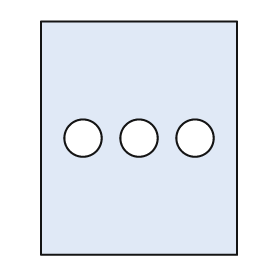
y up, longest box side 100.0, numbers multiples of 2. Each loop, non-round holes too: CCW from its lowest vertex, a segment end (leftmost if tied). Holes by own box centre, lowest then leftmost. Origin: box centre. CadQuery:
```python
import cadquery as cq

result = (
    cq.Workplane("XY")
    .moveTo(-42.0, -50.0)
    .lineTo(42.0, -50.0)
    .lineTo(42.0, 50.0)
    .lineTo(-42.0, 50.0)
    .close()
    .moveTo(-24.0, 0.0)
    .circle(8.0)
    .moveTo(0.0, 0.0)
    .circle(8.0)
    .moveTo(24.0, 0.0)
    .circle(8.0)
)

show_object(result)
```